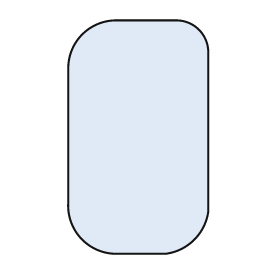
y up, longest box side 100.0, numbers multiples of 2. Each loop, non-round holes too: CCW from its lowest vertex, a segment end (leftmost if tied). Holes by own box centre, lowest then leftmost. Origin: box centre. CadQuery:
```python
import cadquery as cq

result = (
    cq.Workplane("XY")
    .moveTo(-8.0, -50.0)
    .lineTo(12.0, -50.0)
    .threePointArc((24.0, -44.0), (30.0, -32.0))
    .lineTo(30.0, 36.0)
    .threePointArc((26.0, 46.0), (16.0, 50.0))
    .lineTo(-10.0, 50.0)
    .threePointArc((-24.0, 44.0), (-30.0, 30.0))
    .lineTo(-30.0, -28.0)
    .threePointArc((-24.0, -44.0), (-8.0, -50.0))
    .close()
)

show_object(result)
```